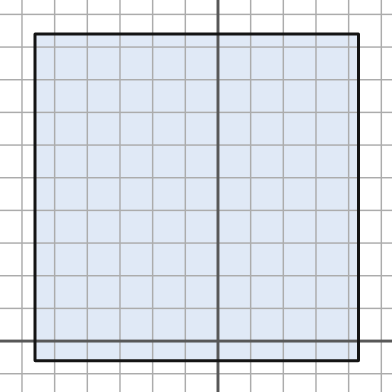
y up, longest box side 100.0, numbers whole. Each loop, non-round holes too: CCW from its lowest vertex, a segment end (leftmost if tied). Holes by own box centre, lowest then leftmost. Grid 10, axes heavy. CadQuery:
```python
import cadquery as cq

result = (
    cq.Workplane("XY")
    .moveTo(-56.0, -6.0)
    .lineTo(43.0, -6.0)
    .lineTo(43.0, 94.0)
    .lineTo(-56.0, 94.0)
    .close()
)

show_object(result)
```